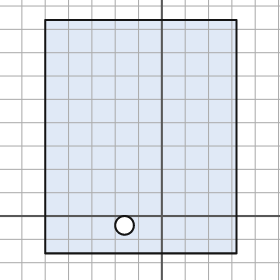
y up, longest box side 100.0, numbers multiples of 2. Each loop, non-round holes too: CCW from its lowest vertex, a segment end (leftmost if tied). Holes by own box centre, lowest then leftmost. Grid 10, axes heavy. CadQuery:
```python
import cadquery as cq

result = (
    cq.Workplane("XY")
    .moveTo(-50.0, -16.0)
    .lineTo(32.0, -16.0)
    .lineTo(32.0, 84.0)
    .lineTo(-50.0, 84.0)
    .close()
    .moveTo(-16.0, -4.0)
    .circle(4.0)
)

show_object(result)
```